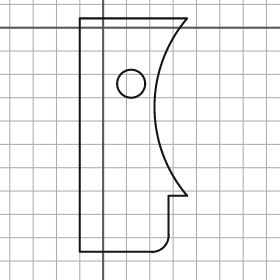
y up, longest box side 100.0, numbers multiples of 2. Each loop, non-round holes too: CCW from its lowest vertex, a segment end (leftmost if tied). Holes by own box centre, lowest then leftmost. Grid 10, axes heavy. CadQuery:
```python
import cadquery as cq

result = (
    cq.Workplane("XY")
    .moveTo(-10.0, -96.0)
    .lineTo(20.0, -96.0)
    .threePointArc((26.0, -94.0), (28.0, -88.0))
    .lineTo(28.0, -72.0)
    .lineTo(36.0, -72.0)
    .threePointArc((22.0, -34.0), (36.0, 4.0))
    .lineTo(-10.0, 4.0)
    .close()
    .moveTo(12.0, -24.0)
    .circle(6.0)
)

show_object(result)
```